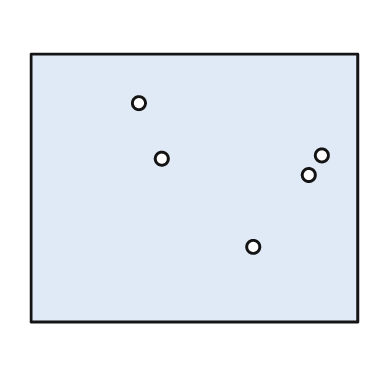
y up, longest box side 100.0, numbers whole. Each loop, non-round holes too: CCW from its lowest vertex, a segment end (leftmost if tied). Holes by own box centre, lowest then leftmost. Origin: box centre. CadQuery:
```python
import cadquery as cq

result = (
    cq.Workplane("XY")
    .moveTo(-50.0, -41.0)
    .lineTo(50.0, -41.0)
    .lineTo(50.0, 41.0)
    .lineTo(-50.0, 41.0)
    .close()
    .moveTo(18.0, -18.0)
    .circle(2.0)
    .moveTo(35.0, 4.0)
    .circle(2.0)
    .moveTo(-10.0, 9.0)
    .circle(2.0)
    .moveTo(39.0, 10.0)
    .circle(2.0)
    .moveTo(-17.0, 26.0)
    .circle(2.0)
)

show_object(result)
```